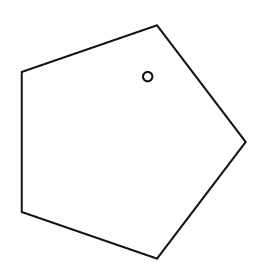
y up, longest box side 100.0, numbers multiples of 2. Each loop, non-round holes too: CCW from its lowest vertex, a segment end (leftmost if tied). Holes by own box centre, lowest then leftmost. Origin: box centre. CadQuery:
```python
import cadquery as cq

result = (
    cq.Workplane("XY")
    .moveTo(10.0, -50.0)
    .lineTo(48.0, 0.0)
    .lineTo(10.0, 50.0)
    .lineTo(-48.0, 30.0)
    .lineTo(-48.0, -30.0)
    .close()
    .moveTo(6.0, 28.0)
    .circle(2.0)
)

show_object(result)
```